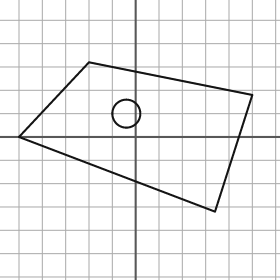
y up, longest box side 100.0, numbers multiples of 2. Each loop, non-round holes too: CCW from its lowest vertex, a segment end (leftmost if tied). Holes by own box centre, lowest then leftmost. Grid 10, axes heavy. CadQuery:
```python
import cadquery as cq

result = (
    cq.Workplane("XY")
    .moveTo(34.0, -32.0)
    .lineTo(50.0, 18.0)
    .lineTo(-20.0, 32.0)
    .lineTo(-50.0, 0.0)
    .close()
    .moveTo(-4.0, 10.0)
    .circle(6.0)
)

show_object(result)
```